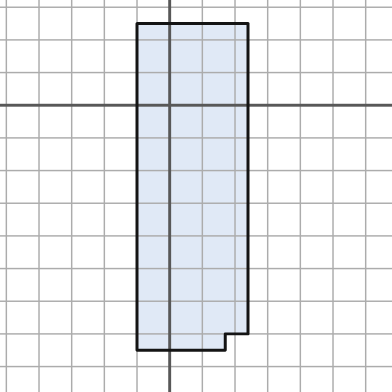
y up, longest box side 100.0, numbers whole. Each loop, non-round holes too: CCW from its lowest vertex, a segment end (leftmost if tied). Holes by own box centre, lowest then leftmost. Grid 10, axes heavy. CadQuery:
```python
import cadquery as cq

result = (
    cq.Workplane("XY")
    .moveTo(-10.0, -75.0)
    .lineTo(17.0, -75.0)
    .lineTo(17.0, -70.0)
    .lineTo(24.0, -70.0)
    .lineTo(24.0, 25.0)
    .lineTo(-10.0, 25.0)
    .close()
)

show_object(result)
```